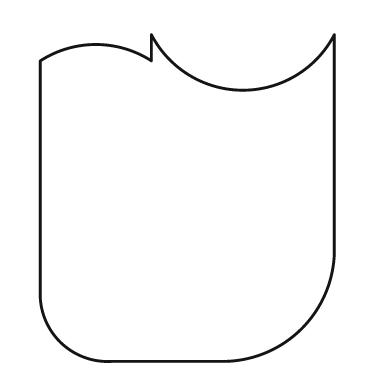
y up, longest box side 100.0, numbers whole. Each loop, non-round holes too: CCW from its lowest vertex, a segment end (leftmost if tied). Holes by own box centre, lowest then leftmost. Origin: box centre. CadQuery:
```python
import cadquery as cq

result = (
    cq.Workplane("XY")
    .moveTo(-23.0, -50.0)
    .lineTo(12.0, -50.0)
    .threePointArc((35.0, -40.0), (45.0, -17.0))
    .lineTo(45.0, 50.0)
    .threePointArc((17.0, 33.0), (-11.0, 50.0))
    .lineTo(-11.0, 42.0)
    .threePointArc((-28.0, 47.0), (-45.0, 42.0))
    .lineTo(-45.0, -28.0)
    .threePointArc((-39.0, -44.0), (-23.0, -50.0))
    .close()
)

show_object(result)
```